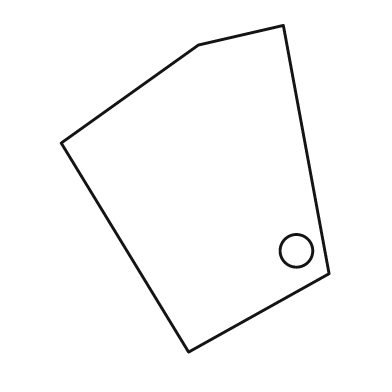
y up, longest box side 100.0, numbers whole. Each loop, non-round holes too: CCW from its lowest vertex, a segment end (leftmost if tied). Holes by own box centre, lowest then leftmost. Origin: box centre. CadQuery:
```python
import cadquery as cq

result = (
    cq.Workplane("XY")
    .moveTo(-2.0, -50.0)
    .lineTo(41.0, -26.0)
    .lineTo(27.0, 50.0)
    .lineTo(1.0, 44.0)
    .lineTo(-41.0, 14.0)
    .close()
    .moveTo(31.0, -19.0)
    .circle(5.0)
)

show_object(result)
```